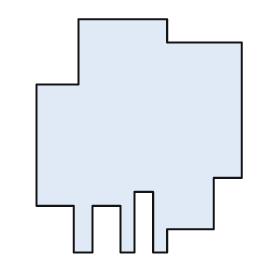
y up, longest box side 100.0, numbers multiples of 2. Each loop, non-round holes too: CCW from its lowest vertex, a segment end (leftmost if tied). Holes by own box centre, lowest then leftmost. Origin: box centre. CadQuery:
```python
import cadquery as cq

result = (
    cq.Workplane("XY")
    .moveTo(-28.0, -50.0)
    .lineTo(-20.0, -50.0)
    .lineTo(-20.0, -30.0)
    .lineTo(-8.0, -30.0)
    .lineTo(-8.0, -50.0)
    .lineTo(-2.0, -50.0)
    .lineTo(-2.0, -24.0)
    .lineTo(6.0, -24.0)
    .lineTo(6.0, -50.0)
    .lineTo(12.0, -50.0)
    .lineTo(12.0, -40.0)
    .lineTo(32.0, -40.0)
    .lineTo(32.0, -18.0)
    .lineTo(44.0, -18.0)
    .lineTo(44.0, 40.0)
    .lineTo(12.0, 40.0)
    .lineTo(12.0, 50.0)
    .lineTo(-26.0, 50.0)
    .lineTo(-26.0, 22.0)
    .lineTo(-44.0, 22.0)
    .lineTo(-44.0, -30.0)
    .lineTo(-28.0, -30.0)
    .close()
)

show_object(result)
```